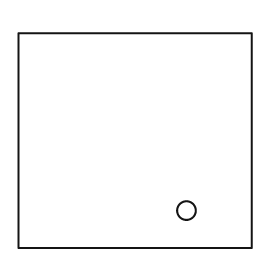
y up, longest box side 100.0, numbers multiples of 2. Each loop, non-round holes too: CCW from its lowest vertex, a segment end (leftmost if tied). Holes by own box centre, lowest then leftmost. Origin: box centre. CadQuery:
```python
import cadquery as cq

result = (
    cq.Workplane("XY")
    .moveTo(-50.0, -46.0)
    .lineTo(50.0, -46.0)
    .lineTo(50.0, 46.0)
    .lineTo(-50.0, 46.0)
    .close()
    .moveTo(22.0, -30.0)
    .circle(4.0)
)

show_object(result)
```